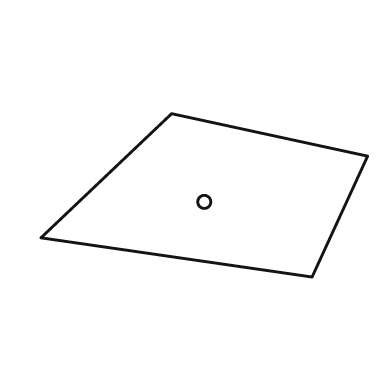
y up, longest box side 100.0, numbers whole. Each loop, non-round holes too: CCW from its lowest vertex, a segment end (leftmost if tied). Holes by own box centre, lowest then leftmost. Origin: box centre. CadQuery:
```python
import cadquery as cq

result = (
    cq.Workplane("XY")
    .moveTo(33.0, -25.0)
    .lineTo(50.0, 12.0)
    .lineTo(-10.0, 25.0)
    .lineTo(-50.0, -13.0)
    .close()
    .moveTo(0.0, -2.0)
    .circle(2.0)
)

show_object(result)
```